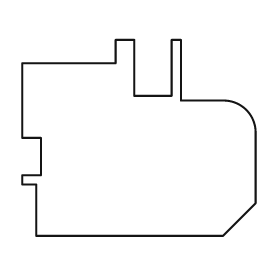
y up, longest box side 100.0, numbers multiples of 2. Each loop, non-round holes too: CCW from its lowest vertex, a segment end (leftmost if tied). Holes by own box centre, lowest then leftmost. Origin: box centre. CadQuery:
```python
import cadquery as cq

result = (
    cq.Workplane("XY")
    .moveTo(-44.0, -42.0)
    .lineTo(36.0, -42.0)
    .lineTo(50.0, -28.0)
    .lineTo(50.0, 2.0)
    .threePointArc((46.0, 12.0), (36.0, 16.0))
    .lineTo(18.0, 16.0)
    .lineTo(18.0, 42.0)
    .lineTo(14.0, 42.0)
    .lineTo(14.0, 18.0)
    .lineTo(-2.0, 18.0)
    .lineTo(-2.0, 42.0)
    .lineTo(-10.0, 42.0)
    .lineTo(-10.0, 32.0)
    .lineTo(-50.0, 32.0)
    .lineTo(-50.0, 0.0)
    .lineTo(-42.0, 0.0)
    .lineTo(-42.0, -16.0)
    .lineTo(-50.0, -16.0)
    .lineTo(-50.0, -20.0)
    .lineTo(-44.0, -20.0)
    .close()
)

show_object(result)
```